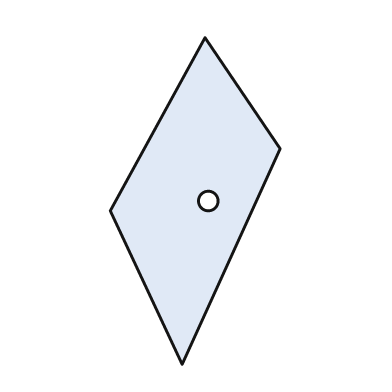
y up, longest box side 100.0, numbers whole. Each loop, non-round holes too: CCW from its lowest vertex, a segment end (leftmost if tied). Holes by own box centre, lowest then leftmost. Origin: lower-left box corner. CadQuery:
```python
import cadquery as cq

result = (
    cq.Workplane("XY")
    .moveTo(22.0, 0.0)
    .lineTo(52.0, 66.0)
    .lineTo(29.0, 100.0)
    .lineTo(0.0, 47.0)
    .close()
    .moveTo(30.0, 50.0)
    .circle(3.0)
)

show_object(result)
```